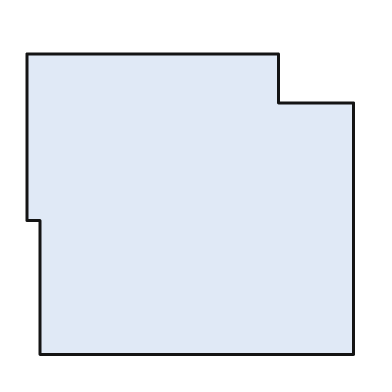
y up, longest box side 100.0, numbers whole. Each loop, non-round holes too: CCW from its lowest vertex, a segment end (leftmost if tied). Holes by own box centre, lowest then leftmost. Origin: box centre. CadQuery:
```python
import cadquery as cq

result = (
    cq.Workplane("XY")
    .moveTo(-46.0, -46.0)
    .lineTo(50.0, -46.0)
    .lineTo(50.0, 31.0)
    .lineTo(27.0, 31.0)
    .lineTo(27.0, 46.0)
    .lineTo(-50.0, 46.0)
    .lineTo(-50.0, -5.0)
    .lineTo(-46.0, -5.0)
    .close()
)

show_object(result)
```